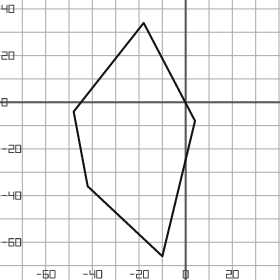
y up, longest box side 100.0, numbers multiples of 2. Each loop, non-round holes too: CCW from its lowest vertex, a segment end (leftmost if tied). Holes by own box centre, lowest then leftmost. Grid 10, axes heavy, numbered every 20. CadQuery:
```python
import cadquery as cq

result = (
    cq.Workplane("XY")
    .moveTo(-10.0, -66.0)
    .lineTo(4.0, -8.0)
    .lineTo(-18.0, 34.0)
    .lineTo(-48.0, -4.0)
    .lineTo(-42.0, -36.0)
    .close()
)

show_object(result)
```